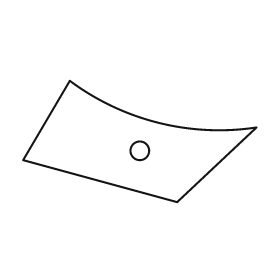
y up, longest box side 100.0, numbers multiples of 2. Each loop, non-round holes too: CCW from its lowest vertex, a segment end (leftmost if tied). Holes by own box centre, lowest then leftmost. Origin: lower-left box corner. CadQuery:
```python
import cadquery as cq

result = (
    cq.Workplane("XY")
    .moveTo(66.0, 0.0)
    .lineTo(100.0, 32.0)
    .threePointArc((58.0, 34.0), (20.0, 52.0))
    .lineTo(0.0, 18.0)
    .close()
    .moveTo(50.0, 22.0)
    .circle(4.0)
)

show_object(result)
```